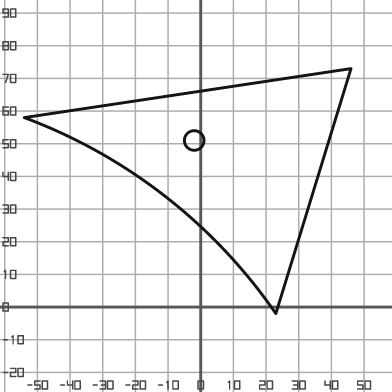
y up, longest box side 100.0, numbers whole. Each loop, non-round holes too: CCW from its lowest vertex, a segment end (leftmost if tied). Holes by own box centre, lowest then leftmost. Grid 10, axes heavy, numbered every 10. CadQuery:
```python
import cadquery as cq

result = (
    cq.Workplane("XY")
    .moveTo(23.0, -2.0)
    .lineTo(46.0, 73.0)
    .lineTo(-54.0, 58.0)
    .threePointArc((-11.0, 34.0), (23.0, -2.0))
    .close()
    .moveTo(-2.0, 51.0)
    .circle(3.0)
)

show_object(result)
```